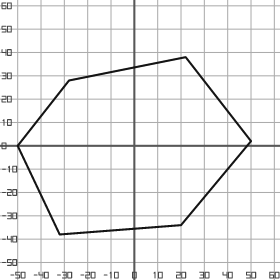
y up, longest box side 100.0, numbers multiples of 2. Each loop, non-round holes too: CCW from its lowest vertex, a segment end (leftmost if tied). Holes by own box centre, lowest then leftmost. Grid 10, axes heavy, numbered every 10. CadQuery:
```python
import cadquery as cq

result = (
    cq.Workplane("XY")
    .moveTo(-32.0, -38.0)
    .lineTo(20.0, -34.0)
    .lineTo(50.0, 2.0)
    .lineTo(22.0, 38.0)
    .lineTo(-28.0, 28.0)
    .lineTo(-50.0, 0.0)
    .close()
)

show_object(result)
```